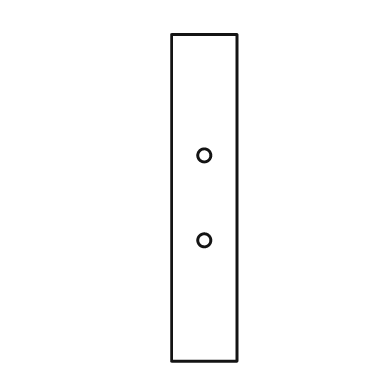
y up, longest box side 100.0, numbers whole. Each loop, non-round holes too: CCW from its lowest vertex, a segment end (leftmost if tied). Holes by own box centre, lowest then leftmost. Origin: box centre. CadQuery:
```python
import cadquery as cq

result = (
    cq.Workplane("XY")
    .moveTo(-10.0, -50.0)
    .lineTo(10.0, -50.0)
    .lineTo(10.0, 50.0)
    .lineTo(-10.0, 50.0)
    .close()
    .moveTo(0.0, -13.0)
    .circle(2.0)
    .moveTo(0.0, 13.0)
    .circle(2.0)
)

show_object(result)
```